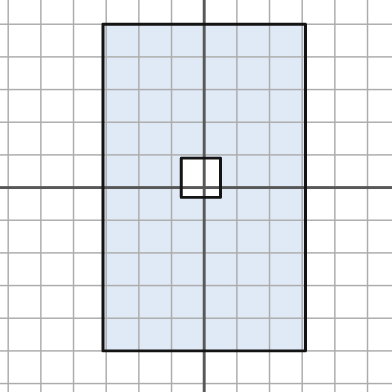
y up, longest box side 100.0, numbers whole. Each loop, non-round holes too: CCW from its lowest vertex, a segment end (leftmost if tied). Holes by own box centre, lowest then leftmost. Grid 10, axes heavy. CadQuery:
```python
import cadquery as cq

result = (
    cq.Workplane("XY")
    .moveTo(-31.0, -50.0)
    .lineTo(31.0, -50.0)
    .lineTo(31.0, 50.0)
    .lineTo(-31.0, 50.0)
    .close()
    .moveTo(-7.0, -3.0)
    .lineTo(5.0, -3.0)
    .lineTo(5.0, 9.0)
    .lineTo(-7.0, 9.0)
    .close()
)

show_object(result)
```